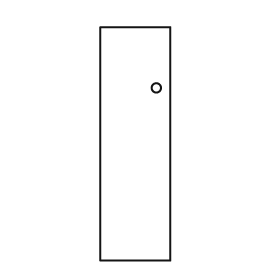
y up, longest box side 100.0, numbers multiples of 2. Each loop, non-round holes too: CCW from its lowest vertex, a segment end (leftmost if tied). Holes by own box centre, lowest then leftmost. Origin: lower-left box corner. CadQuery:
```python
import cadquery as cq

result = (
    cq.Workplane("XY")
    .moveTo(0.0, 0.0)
    .lineTo(30.0, 0.0)
    .lineTo(30.0, 100.0)
    .lineTo(0.0, 100.0)
    .close()
    .moveTo(24.0, 74.0)
    .circle(2.0)
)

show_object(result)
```